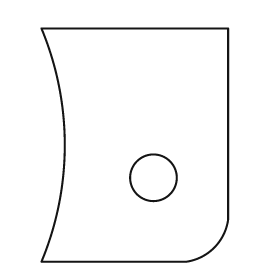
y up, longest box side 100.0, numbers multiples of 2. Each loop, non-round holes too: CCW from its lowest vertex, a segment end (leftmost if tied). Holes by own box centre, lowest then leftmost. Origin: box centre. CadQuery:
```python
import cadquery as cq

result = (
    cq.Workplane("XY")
    .moveTo(-40.0, -50.0)
    .lineTo(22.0, -50.0)
    .threePointArc((34.0, -44.0), (40.0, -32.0))
    .lineTo(40.0, 50.0)
    .lineTo(-40.0, 50.0)
    .threePointArc((-30.0, 0.0), (-40.0, -50.0))
    .close()
    .moveTo(8.0, -14.0)
    .circle(10.0)
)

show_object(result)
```